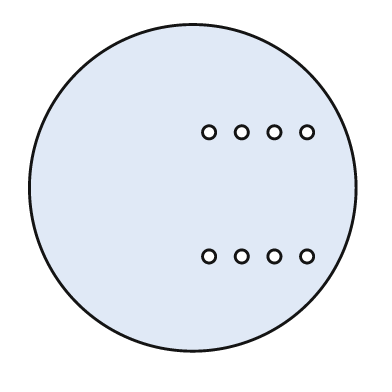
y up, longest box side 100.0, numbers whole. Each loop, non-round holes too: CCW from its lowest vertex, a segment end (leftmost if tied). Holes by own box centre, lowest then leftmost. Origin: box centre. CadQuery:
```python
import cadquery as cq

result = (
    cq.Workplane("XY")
    .moveTo(0.0, 0.0)
    .circle(50.0)
    .moveTo(5.0, -21.0)
    .circle(2.0)
    .moveTo(15.0, -21.0)
    .circle(2.0)
    .moveTo(25.0, -21.0)
    .circle(2.0)
    .moveTo(35.0, -21.0)
    .circle(2.0)
    .moveTo(5.0, 17.0)
    .circle(2.0)
    .moveTo(15.0, 17.0)
    .circle(2.0)
    .moveTo(25.0, 17.0)
    .circle(2.0)
    .moveTo(35.0, 17.0)
    .circle(2.0)
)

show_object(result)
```